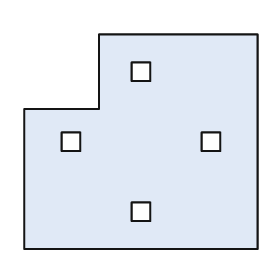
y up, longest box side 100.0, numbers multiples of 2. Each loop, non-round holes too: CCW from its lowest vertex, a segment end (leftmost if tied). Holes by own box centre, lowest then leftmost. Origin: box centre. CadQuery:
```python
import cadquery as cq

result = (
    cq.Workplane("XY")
    .moveTo(-50.0, -46.0)
    .lineTo(50.0, -46.0)
    .lineTo(50.0, 46.0)
    .lineTo(-18.0, 46.0)
    .lineTo(-18.0, 14.0)
    .lineTo(-50.0, 14.0)
    .close()
    .moveTo(-4.0, -34.0)
    .lineTo(4.0, -34.0)
    .lineTo(4.0, -26.0)
    .lineTo(-4.0, -26.0)
    .close()
    .moveTo(-34.0, -4.0)
    .lineTo(-26.0, -4.0)
    .lineTo(-26.0, 4.0)
    .lineTo(-34.0, 4.0)
    .close()
    .moveTo(26.0, -4.0)
    .lineTo(34.0, -4.0)
    .lineTo(34.0, 4.0)
    .lineTo(26.0, 4.0)
    .close()
    .moveTo(-4.0, 26.0)
    .lineTo(4.0, 26.0)
    .lineTo(4.0, 34.0)
    .lineTo(-4.0, 34.0)
    .close()
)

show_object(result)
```